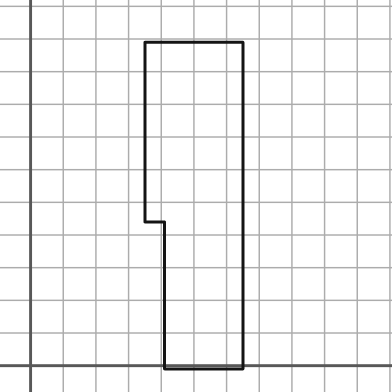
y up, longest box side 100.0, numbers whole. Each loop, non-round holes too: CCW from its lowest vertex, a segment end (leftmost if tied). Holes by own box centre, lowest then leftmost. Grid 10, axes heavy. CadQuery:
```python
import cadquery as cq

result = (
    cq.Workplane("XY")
    .moveTo(41.0, -1.0)
    .lineTo(65.0, -1.0)
    .lineTo(65.0, 99.0)
    .lineTo(35.0, 99.0)
    .lineTo(35.0, 44.0)
    .lineTo(41.0, 44.0)
    .close()
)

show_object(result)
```